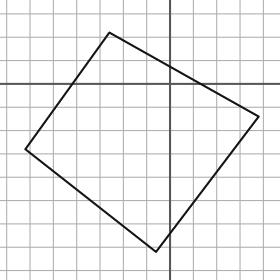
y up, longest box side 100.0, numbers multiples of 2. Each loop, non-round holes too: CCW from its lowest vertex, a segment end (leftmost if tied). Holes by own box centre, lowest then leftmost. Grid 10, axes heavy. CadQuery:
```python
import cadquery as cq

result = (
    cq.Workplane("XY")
    .moveTo(-6.0, -72.0)
    .lineTo(38.0, -14.0)
    .lineTo(-26.0, 22.0)
    .lineTo(-62.0, -28.0)
    .close()
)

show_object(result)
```